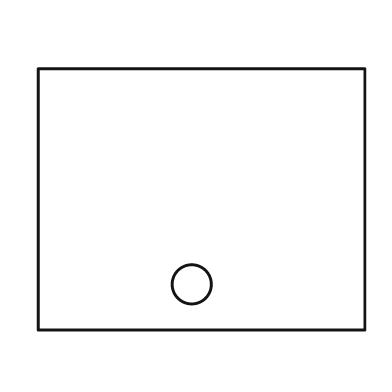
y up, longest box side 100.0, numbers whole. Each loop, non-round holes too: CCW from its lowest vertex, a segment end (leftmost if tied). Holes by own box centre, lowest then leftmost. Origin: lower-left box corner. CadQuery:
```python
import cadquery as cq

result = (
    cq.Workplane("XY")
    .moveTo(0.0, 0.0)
    .lineTo(100.0, 0.0)
    .lineTo(100.0, 80.0)
    .lineTo(0.0, 80.0)
    .close()
    .moveTo(47.0, 14.0)
    .circle(6.0)
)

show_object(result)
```